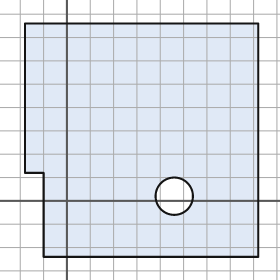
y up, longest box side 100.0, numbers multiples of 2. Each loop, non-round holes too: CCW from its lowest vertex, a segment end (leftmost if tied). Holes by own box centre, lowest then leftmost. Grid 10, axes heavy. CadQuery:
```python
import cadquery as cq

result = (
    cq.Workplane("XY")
    .moveTo(-10.0, -24.0)
    .lineTo(82.0, -24.0)
    .lineTo(82.0, 76.0)
    .lineTo(-18.0, 76.0)
    .lineTo(-18.0, 12.0)
    .lineTo(-10.0, 12.0)
    .close()
    .moveTo(46.0, 2.0)
    .circle(8.0)
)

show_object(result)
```